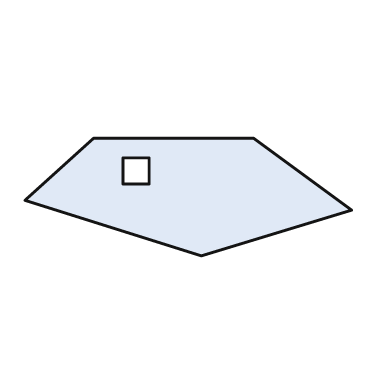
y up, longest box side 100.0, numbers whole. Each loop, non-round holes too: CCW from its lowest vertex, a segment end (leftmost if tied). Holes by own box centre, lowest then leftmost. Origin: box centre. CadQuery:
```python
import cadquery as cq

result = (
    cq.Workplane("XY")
    .moveTo(4.0, -18.0)
    .lineTo(50.0, -4.0)
    .lineTo(20.0, 18.0)
    .lineTo(-29.0, 18.0)
    .lineTo(-50.0, -1.0)
    .close()
    .moveTo(-20.0, 4.0)
    .lineTo(-12.0, 4.0)
    .lineTo(-12.0, 12.0)
    .lineTo(-20.0, 12.0)
    .close()
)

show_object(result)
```